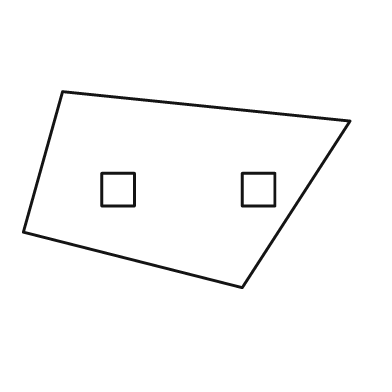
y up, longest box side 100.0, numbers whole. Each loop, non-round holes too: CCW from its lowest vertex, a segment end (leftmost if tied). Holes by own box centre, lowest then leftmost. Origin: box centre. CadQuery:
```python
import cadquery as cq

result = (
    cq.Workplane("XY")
    .moveTo(17.0, -30.0)
    .lineTo(50.0, 21.0)
    .lineTo(-38.0, 30.0)
    .lineTo(-50.0, -13.0)
    .close()
    .moveTo(-26.0, -5.0)
    .lineTo(-16.0, -5.0)
    .lineTo(-16.0, 5.0)
    .lineTo(-26.0, 5.0)
    .close()
    .moveTo(17.0, -5.0)
    .lineTo(27.0, -5.0)
    .lineTo(27.0, 5.0)
    .lineTo(17.0, 5.0)
    .close()
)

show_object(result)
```